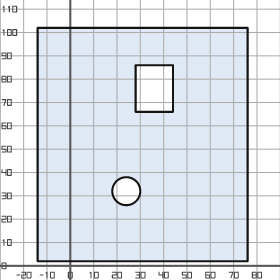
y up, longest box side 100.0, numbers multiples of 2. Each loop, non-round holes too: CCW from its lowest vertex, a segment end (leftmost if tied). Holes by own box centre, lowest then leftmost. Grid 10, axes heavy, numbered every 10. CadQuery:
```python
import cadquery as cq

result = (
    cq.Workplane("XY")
    .moveTo(-14.0, 2.0)
    .lineTo(76.0, 2.0)
    .lineTo(76.0, 102.0)
    .lineTo(-14.0, 102.0)
    .close()
    .moveTo(24.0, 32.0)
    .circle(6.0)
    .moveTo(28.0, 66.0)
    .lineTo(44.0, 66.0)
    .lineTo(44.0, 86.0)
    .lineTo(28.0, 86.0)
    .close()
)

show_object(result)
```